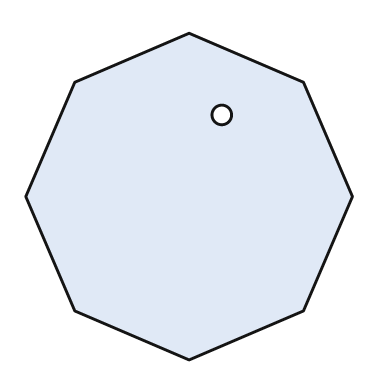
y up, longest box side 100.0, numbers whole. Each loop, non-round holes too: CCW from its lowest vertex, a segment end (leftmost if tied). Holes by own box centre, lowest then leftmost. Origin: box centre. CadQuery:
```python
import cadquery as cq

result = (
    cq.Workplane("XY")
    .moveTo(0.0, -50.0)
    .lineTo(35.0, -35.0)
    .lineTo(50.0, 0.0)
    .lineTo(35.0, 35.0)
    .lineTo(0.0, 50.0)
    .lineTo(-35.0, 35.0)
    .lineTo(-50.0, 0.0)
    .lineTo(-35.0, -35.0)
    .close()
    .moveTo(10.0, 25.0)
    .circle(3.0)
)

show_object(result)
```